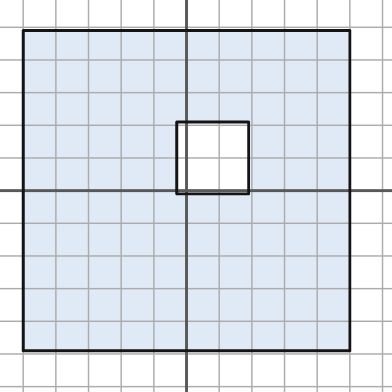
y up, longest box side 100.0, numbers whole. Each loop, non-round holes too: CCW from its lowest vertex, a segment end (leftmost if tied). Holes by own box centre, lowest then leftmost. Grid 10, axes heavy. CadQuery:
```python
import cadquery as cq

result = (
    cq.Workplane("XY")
    .moveTo(-50.0, -49.0)
    .lineTo(50.0, -49.0)
    .lineTo(50.0, 49.0)
    .lineTo(-50.0, 49.0)
    .close()
    .moveTo(-3.0, -1.0)
    .lineTo(19.0, -1.0)
    .lineTo(19.0, 21.0)
    .lineTo(-3.0, 21.0)
    .close()
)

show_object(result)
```